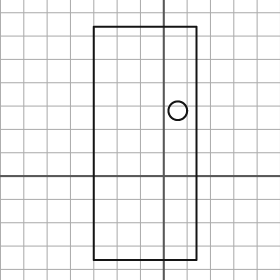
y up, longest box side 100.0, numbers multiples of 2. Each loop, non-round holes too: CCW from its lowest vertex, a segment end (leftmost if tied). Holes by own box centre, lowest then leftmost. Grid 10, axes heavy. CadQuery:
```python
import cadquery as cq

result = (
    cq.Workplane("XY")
    .moveTo(-30.0, -36.0)
    .lineTo(14.0, -36.0)
    .lineTo(14.0, 64.0)
    .lineTo(-30.0, 64.0)
    .close()
    .moveTo(6.0, 28.0)
    .circle(4.0)
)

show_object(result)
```